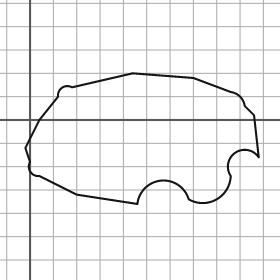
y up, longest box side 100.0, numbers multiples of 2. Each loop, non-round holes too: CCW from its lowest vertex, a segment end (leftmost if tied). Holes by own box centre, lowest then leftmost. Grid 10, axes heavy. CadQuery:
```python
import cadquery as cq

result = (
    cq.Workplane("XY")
    .moveTo(46.0, -36.0)
    .threePointArc((56.0, -26.0), (68.0, -34.0))
    .threePointArc((80.0, -34.0), (86.0, -24.0))
    .threePointArc((88.0, -14.0), (98.0, -16.0))
    .lineTo(96.0, 2.0)
    .lineTo(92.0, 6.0)
    .threePointArc((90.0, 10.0), (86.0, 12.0))
    .lineTo(70.0, 18.0)
    .lineTo(44.0, 20.0)
    .lineTo(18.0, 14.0)
    .threePointArc((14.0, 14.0), (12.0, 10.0))
    .lineTo(4.0, 0.0)
    .lineTo(-2.0, -12.0)
    .lineTo(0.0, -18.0)
    .threePointArc((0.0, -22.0), (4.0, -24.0))
    .lineTo(20.0, -32.0)
    .close()
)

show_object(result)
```